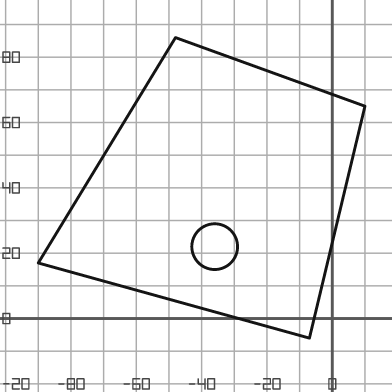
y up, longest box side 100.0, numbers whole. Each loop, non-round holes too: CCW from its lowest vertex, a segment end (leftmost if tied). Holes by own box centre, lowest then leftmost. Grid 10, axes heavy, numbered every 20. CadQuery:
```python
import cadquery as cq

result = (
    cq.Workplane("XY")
    .moveTo(-7.0, -6.0)
    .lineTo(10.0, 65.0)
    .lineTo(-48.0, 86.0)
    .lineTo(-90.0, 17.0)
    .close()
    .moveTo(-36.0, 22.0)
    .circle(7.0)
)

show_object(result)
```